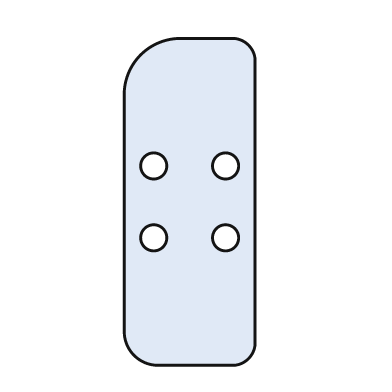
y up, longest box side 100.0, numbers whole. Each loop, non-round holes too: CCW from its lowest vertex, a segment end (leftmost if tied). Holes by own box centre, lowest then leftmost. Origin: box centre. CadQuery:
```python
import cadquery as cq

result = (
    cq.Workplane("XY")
    .moveTo(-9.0, -50.0)
    .lineTo(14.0, -50.0)
    .threePointArc((18.0, -48.0), (20.0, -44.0))
    .lineTo(20.0, 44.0)
    .threePointArc((18.0, 48.0), (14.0, 50.0))
    .lineTo(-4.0, 50.0)
    .threePointArc((-15.0, 45.0), (-20.0, 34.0))
    .lineTo(-20.0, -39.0)
    .threePointArc((-17.0, -47.0), (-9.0, -50.0))
    .close()
    .moveTo(-11.0, -11.0)
    .circle(4.0)
    .moveTo(11.0, -11.0)
    .circle(4.0)
    .moveTo(-11.0, 11.0)
    .circle(4.0)
    .moveTo(11.0, 11.0)
    .circle(4.0)
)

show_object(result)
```